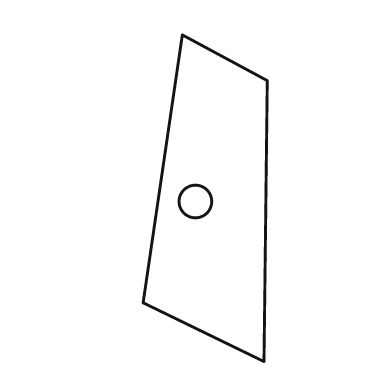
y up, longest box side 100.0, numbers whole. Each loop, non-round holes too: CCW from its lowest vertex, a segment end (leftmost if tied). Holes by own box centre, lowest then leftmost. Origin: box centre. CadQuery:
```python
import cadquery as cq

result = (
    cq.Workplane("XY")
    .moveTo(18.0, -50.0)
    .lineTo(19.0, 36.0)
    .lineTo(-7.0, 50.0)
    .lineTo(-19.0, -32.0)
    .close()
    .moveTo(-3.0, -1.0)
    .circle(5.0)
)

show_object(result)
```